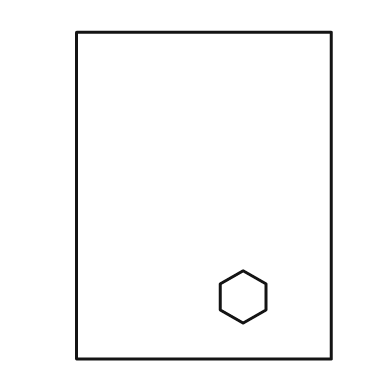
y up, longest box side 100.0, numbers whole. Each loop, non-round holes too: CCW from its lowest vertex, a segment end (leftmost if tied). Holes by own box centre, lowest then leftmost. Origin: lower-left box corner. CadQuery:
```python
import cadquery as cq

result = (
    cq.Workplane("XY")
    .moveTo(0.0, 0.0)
    .lineTo(78.0, 0.0)
    .lineTo(78.0, 100.0)
    .lineTo(0.0, 100.0)
    .close()
    .moveTo(51.0, 11.0)
    .lineTo(58.0, 15.0)
    .lineTo(58.0, 23.0)
    .lineTo(51.0, 27.0)
    .lineTo(44.0, 23.0)
    .lineTo(44.0, 15.0)
    .close()
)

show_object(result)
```